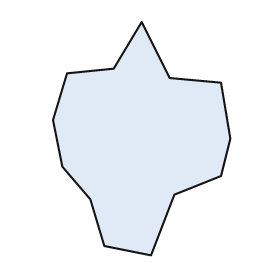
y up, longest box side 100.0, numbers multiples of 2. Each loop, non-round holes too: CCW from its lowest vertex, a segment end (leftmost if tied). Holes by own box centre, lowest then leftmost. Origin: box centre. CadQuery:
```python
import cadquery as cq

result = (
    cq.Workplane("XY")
    .moveTo(4.0, -50.0)
    .lineTo(14.0, -24.0)
    .lineTo(34.0, -16.0)
    .lineTo(38.0, 0.0)
    .lineTo(34.0, 24.0)
    .lineTo(12.0, 26.0)
    .lineTo(0.0, 50.0)
    .lineTo(-12.0, 30.0)
    .lineTo(-32.0, 28.0)
    .lineTo(-38.0, 8.0)
    .lineTo(-34.0, -12.0)
    .lineTo(-22.0, -26.0)
    .lineTo(-16.0, -46.0)
    .close()
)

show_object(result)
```